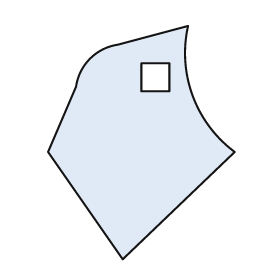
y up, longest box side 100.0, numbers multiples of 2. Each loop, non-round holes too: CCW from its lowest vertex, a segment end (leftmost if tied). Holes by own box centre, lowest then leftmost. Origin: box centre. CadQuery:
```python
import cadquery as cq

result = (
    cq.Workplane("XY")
    .moveTo(-8.0, -50.0)
    .lineTo(40.0, -4.0)
    .threePointArc((22.0, 20.0), (20.0, 50.0))
    .lineTo(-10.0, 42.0)
    .threePointArc((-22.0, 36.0), (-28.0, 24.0))
    .lineTo(-40.0, -4.0)
    .close()
    .moveTo(0.0, 22.0)
    .lineTo(12.0, 22.0)
    .lineTo(12.0, 34.0)
    .lineTo(0.0, 34.0)
    .close()
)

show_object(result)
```